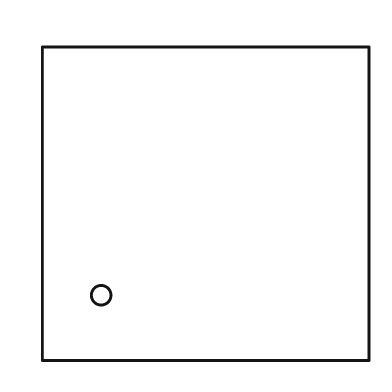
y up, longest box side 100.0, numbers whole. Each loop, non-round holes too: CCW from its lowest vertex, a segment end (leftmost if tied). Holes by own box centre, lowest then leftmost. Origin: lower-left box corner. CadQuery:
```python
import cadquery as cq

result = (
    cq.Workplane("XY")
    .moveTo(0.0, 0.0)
    .lineTo(100.0, 0.0)
    .lineTo(100.0, 96.0)
    .lineTo(0.0, 96.0)
    .close()
    .moveTo(18.0, 20.0)
    .circle(3.0)
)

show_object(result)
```